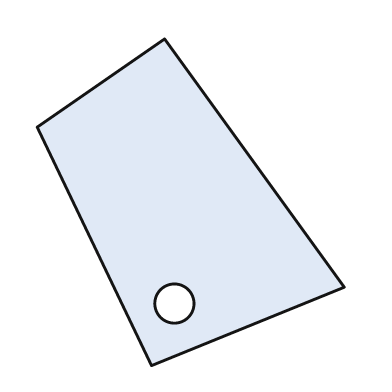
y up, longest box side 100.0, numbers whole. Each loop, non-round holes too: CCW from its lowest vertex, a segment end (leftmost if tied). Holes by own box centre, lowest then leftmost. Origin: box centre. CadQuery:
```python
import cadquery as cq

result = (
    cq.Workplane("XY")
    .moveTo(-12.0, -50.0)
    .lineTo(47.0, -26.0)
    .lineTo(-8.0, 50.0)
    .lineTo(-47.0, 23.0)
    .close()
    .moveTo(-5.0, -31.0)
    .circle(6.0)
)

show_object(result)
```